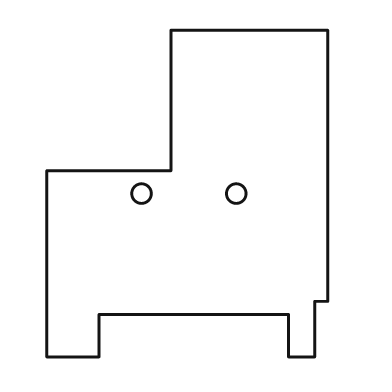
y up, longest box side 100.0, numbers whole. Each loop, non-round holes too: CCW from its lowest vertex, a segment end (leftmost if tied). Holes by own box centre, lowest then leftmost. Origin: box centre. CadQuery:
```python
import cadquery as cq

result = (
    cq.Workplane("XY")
    .moveTo(-43.0, -50.0)
    .lineTo(-27.0, -50.0)
    .lineTo(-27.0, -37.0)
    .lineTo(31.0, -37.0)
    .lineTo(31.0, -50.0)
    .lineTo(39.0, -50.0)
    .lineTo(39.0, -33.0)
    .lineTo(43.0, -33.0)
    .lineTo(43.0, 50.0)
    .lineTo(-5.0, 50.0)
    .lineTo(-5.0, 7.0)
    .lineTo(-43.0, 7.0)
    .close()
    .moveTo(-14.0, 0.0)
    .circle(3.0)
    .moveTo(15.0, 0.0)
    .circle(3.0)
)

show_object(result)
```